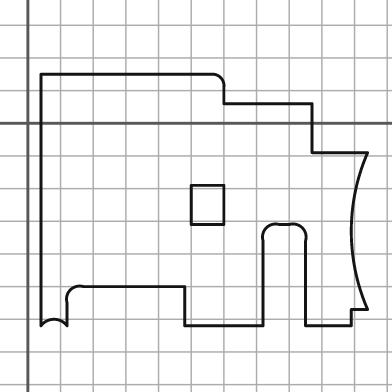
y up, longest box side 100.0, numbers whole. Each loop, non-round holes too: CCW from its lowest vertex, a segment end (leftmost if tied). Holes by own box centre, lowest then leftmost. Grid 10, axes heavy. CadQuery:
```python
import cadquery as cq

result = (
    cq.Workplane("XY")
    .moveTo(4.0, -62.0)
    .threePointArc((8.0, -60.0), (12.0, -62.0))
    .lineTo(12.0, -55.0)
    .threePointArc((13.0, -51.0), (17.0, -50.0))
    .lineTo(48.0, -50.0)
    .lineTo(48.0, -62.0)
    .lineTo(72.0, -62.0)
    .lineTo(72.0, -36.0)
    .threePointArc((73.0, -32.0), (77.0, -31.0))
    .lineTo(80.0, -31.0)
    .threePointArc((84.0, -32.0), (85.0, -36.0))
    .lineTo(85.0, -62.0)
    .lineTo(99.0, -62.0)
    .lineTo(99.0, -57.0)
    .lineTo(104.0, -57.0)
    .threePointArc((99.0, -33.0), (104.0, -9.0))
    .lineTo(87.0, -9.0)
    .lineTo(87.0, 6.0)
    .lineTo(60.0, 6.0)
    .lineTo(60.0, 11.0)
    .threePointArc((59.0, 14.0), (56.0, 15.0))
    .lineTo(4.0, 15.0)
    .close()
    .moveTo(50.0, -31.0)
    .lineTo(60.0, -31.0)
    .lineTo(60.0, -19.0)
    .lineTo(50.0, -19.0)
    .close()
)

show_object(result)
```